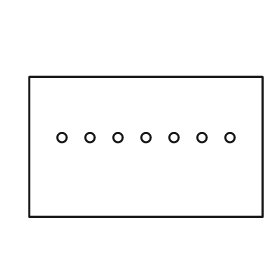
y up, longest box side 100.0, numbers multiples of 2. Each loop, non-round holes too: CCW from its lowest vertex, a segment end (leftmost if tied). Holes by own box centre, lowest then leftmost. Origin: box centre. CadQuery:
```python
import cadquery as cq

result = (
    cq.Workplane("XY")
    .moveTo(-50.0, -30.0)
    .lineTo(50.0, -30.0)
    .lineTo(50.0, 30.0)
    .lineTo(-50.0, 30.0)
    .close()
    .moveTo(-36.0, 4.0)
    .circle(2.0)
    .moveTo(-24.0, 4.0)
    .circle(2.0)
    .moveTo(-12.0, 4.0)
    .circle(2.0)
    .moveTo(0.0, 4.0)
    .circle(2.0)
    .moveTo(12.0, 4.0)
    .circle(2.0)
    .moveTo(24.0, 4.0)
    .circle(2.0)
    .moveTo(36.0, 4.0)
    .circle(2.0)
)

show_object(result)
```